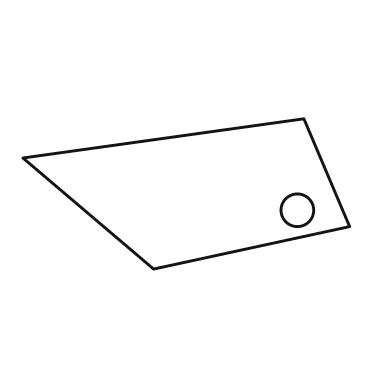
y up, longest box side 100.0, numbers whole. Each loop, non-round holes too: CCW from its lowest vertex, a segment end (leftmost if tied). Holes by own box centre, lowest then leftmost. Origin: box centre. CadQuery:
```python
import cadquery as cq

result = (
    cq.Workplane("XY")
    .moveTo(-10.0, -23.0)
    .lineTo(50.0, -10.0)
    .lineTo(36.0, 23.0)
    .lineTo(-50.0, 11.0)
    .close()
    .moveTo(34.0, -5.0)
    .circle(5.0)
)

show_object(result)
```